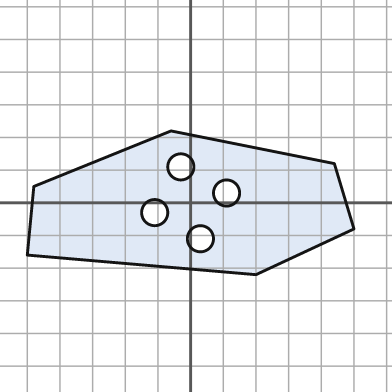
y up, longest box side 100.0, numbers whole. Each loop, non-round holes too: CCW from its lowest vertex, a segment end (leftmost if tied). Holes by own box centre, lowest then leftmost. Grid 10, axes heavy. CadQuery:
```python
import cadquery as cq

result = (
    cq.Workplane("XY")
    .moveTo(20.0, -22.0)
    .lineTo(50.0, -8.0)
    .lineTo(44.0, 12.0)
    .lineTo(-6.0, 22.0)
    .lineTo(-48.0, 5.0)
    .lineTo(-50.0, -16.0)
    .close()
    .moveTo(3.0, -11.0)
    .circle(4.0)
    .moveTo(-11.0, -3.0)
    .circle(4.0)
    .moveTo(11.0, 3.0)
    .circle(4.0)
    .moveTo(-3.0, 11.0)
    .circle(4.0)
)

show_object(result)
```